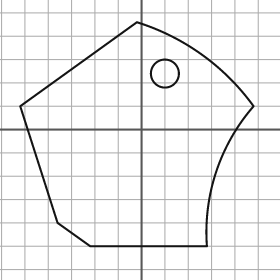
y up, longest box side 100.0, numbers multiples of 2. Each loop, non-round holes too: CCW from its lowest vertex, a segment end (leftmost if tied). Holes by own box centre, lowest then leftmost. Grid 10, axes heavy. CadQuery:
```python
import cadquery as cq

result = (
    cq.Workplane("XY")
    .moveTo(-22.0, -50.0)
    .lineTo(28.0, -50.0)
    .threePointArc((32.0, -18.0), (48.0, 10.0))
    .threePointArc((26.0, 32.0), (-2.0, 46.0))
    .lineTo(-52.0, 10.0)
    .lineTo(-36.0, -40.0)
    .close()
    .moveTo(10.0, 24.0)
    .circle(6.0)
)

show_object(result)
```